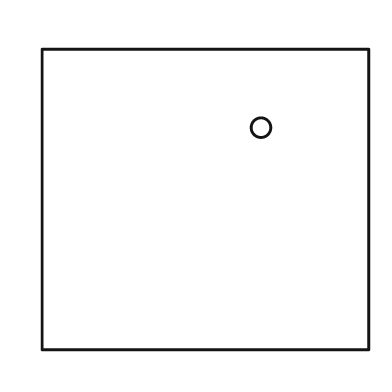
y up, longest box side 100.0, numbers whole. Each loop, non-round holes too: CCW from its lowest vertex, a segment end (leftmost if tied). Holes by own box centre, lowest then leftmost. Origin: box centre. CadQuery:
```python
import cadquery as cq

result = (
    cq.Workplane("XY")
    .moveTo(-50.0, -46.0)
    .lineTo(50.0, -46.0)
    .lineTo(50.0, 46.0)
    .lineTo(-50.0, 46.0)
    .close()
    .moveTo(17.0, 22.0)
    .circle(3.0)
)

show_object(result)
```